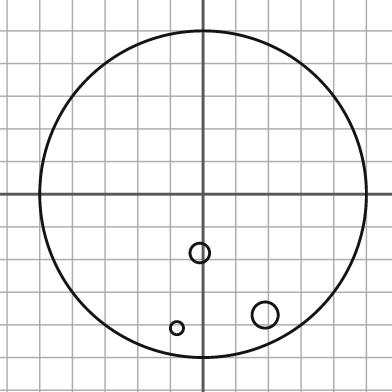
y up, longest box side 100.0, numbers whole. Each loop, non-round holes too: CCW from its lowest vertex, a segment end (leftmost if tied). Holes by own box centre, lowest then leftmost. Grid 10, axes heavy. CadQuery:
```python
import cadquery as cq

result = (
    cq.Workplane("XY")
    .moveTo(0.0, 0.0)
    .circle(50.0)
    .moveTo(-8.0, -41.0)
    .circle(2.0)
    .moveTo(19.0, -37.0)
    .circle(4.0)
    .moveTo(-1.0, -18.0)
    .circle(3.0)
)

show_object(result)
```